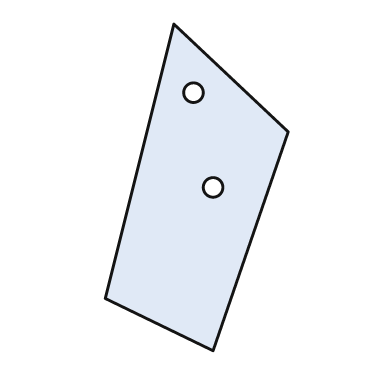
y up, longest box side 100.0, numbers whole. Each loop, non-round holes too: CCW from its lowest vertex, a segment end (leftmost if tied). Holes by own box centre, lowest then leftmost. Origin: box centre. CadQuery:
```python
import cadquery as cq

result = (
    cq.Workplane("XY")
    .moveTo(5.0, -50.0)
    .lineTo(28.0, 17.0)
    .lineTo(-7.0, 50.0)
    .lineTo(-28.0, -34.0)
    .close()
    .moveTo(5.0, 0.0)
    .circle(3.0)
    .moveTo(-1.0, 29.0)
    .circle(3.0)
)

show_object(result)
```